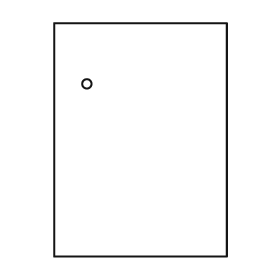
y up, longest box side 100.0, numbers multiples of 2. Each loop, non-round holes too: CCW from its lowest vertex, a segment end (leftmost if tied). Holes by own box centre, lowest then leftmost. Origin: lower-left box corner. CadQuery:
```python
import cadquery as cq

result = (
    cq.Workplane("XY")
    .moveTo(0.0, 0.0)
    .lineTo(74.0, 0.0)
    .lineTo(74.0, 100.0)
    .lineTo(0.0, 100.0)
    .close()
    .moveTo(14.0, 74.0)
    .circle(2.0)
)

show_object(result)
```